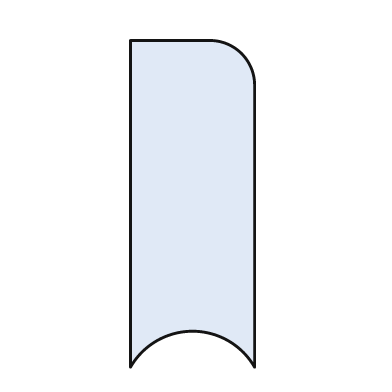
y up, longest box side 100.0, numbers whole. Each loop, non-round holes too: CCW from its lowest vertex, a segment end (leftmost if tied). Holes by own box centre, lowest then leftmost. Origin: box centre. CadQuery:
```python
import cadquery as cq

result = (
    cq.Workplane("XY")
    .moveTo(-19.0, -50.0)
    .threePointArc((0.0, -39.0), (19.0, -50.0))
    .lineTo(19.0, 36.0)
    .threePointArc((15.0, 46.0), (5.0, 50.0))
    .lineTo(-19.0, 50.0)
    .close()
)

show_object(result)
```